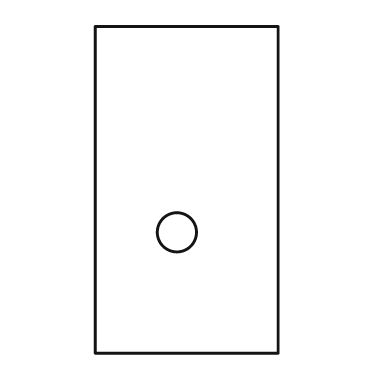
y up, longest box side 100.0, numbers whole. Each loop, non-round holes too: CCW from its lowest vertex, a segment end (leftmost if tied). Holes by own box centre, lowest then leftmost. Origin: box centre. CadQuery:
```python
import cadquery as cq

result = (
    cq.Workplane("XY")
    .moveTo(-28.0, -50.0)
    .lineTo(28.0, -50.0)
    .lineTo(28.0, 50.0)
    .lineTo(-28.0, 50.0)
    .close()
    .moveTo(-3.0, -13.0)
    .circle(6.0)
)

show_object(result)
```